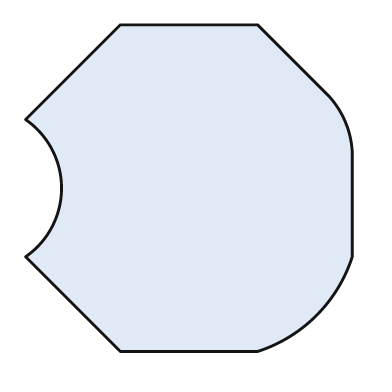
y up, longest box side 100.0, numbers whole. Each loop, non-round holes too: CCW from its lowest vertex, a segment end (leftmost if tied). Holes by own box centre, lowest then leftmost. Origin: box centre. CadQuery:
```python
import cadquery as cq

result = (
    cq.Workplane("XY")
    .moveTo(-21.0, -50.0)
    .lineTo(21.0, -50.0)
    .threePointArc((39.0, -39.0), (50.0, -21.0))
    .lineTo(50.0, 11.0)
    .threePointArc((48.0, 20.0), (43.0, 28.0))
    .lineTo(21.0, 50.0)
    .lineTo(-21.0, 50.0)
    .lineTo(-50.0, 21.0)
    .threePointArc((-39.0, 0.0), (-50.0, -21.0))
    .close()
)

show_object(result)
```